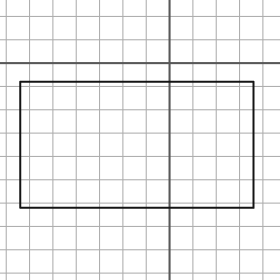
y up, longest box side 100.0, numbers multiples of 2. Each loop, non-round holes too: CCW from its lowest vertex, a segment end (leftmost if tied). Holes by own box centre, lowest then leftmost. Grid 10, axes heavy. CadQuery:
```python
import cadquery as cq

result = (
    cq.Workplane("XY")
    .moveTo(-64.0, -62.0)
    .lineTo(36.0, -62.0)
    .lineTo(36.0, -8.0)
    .lineTo(-64.0, -8.0)
    .close()
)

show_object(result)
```